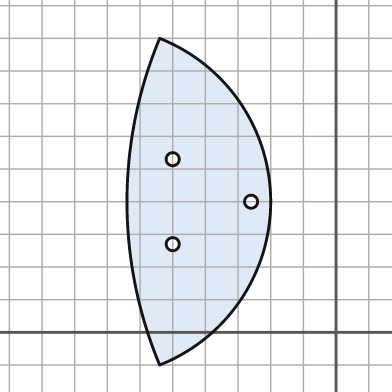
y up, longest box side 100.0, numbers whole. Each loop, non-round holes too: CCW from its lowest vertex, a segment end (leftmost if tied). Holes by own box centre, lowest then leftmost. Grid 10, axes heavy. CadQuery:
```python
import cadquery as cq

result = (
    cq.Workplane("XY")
    .moveTo(-54.0, -10.0)
    .threePointArc((-20.0, 40.0), (-54.0, 90.0))
    .threePointArc((-64.0, 40.0), (-54.0, -10.0))
    .close()
    .moveTo(-50.0, 27.0)
    .circle(2.0)
    .moveTo(-26.0, 40.0)
    .circle(2.0)
    .moveTo(-50.0, 53.0)
    .circle(2.0)
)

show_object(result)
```